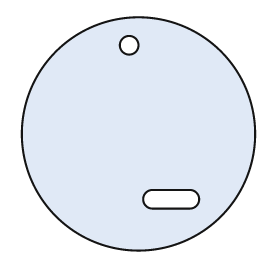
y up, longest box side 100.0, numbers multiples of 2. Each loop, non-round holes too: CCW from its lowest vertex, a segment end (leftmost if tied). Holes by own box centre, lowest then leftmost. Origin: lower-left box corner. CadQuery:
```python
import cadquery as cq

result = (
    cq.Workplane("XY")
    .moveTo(50.0, 50.0)
    .circle(50.0)
    .moveTo(56.0, 18.0)
    .lineTo(72.0, 18.0)
    .threePointArc((76.0, 22.0), (72.0, 26.0))
    .lineTo(56.0, 26.0)
    .threePointArc((52.0, 22.0), (56.0, 18.0))
    .close()
    .moveTo(46.0, 88.0)
    .circle(4.0)
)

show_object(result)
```